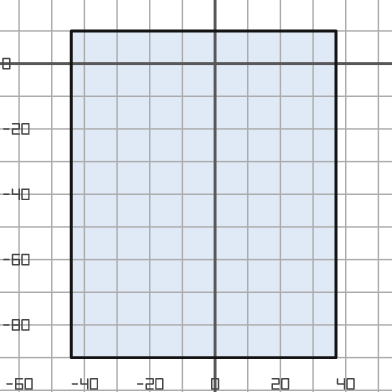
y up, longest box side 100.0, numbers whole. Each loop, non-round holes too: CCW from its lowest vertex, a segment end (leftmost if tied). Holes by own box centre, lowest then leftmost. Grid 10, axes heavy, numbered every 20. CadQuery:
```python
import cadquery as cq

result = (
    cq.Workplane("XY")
    .moveTo(-44.0, -90.0)
    .lineTo(37.0, -90.0)
    .lineTo(37.0, 10.0)
    .lineTo(-44.0, 10.0)
    .close()
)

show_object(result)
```